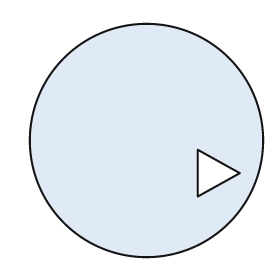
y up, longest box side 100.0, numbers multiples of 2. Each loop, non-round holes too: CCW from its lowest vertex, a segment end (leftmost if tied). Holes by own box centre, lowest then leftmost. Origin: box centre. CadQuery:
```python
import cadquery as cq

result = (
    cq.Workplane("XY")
    .moveTo(0.0, 0.0)
    .circle(50.0)
    .moveTo(22.0, -24.0)
    .lineTo(40.0, -14.0)
    .lineTo(22.0, -4.0)
    .close()
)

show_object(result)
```